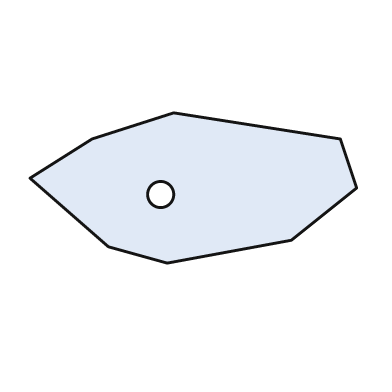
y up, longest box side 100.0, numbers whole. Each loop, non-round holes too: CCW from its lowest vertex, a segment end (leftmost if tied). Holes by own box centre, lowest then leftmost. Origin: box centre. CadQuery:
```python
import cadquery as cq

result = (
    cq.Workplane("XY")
    .moveTo(-8.0, -23.0)
    .lineTo(30.0, -16.0)
    .lineTo(50.0, 0.0)
    .lineTo(45.0, 15.0)
    .lineTo(-6.0, 23.0)
    .lineTo(-31.0, 15.0)
    .lineTo(-50.0, 3.0)
    .lineTo(-26.0, -18.0)
    .close()
    .moveTo(-10.0, -2.0)
    .circle(4.0)
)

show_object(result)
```